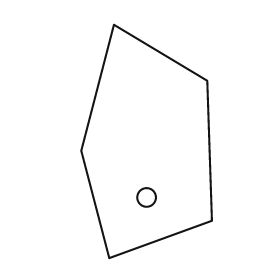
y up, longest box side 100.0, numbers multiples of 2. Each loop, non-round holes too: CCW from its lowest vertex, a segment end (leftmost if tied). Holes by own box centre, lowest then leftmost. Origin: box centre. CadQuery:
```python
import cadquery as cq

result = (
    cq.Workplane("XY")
    .moveTo(-16.0, -50.0)
    .lineTo(28.0, -34.0)
    .lineTo(26.0, 26.0)
    .lineTo(-14.0, 50.0)
    .lineTo(-28.0, -4.0)
    .close()
    .moveTo(0.0, -24.0)
    .circle(4.0)
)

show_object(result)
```